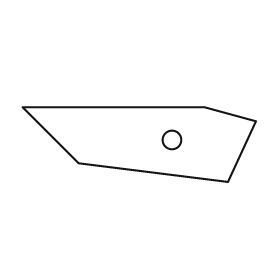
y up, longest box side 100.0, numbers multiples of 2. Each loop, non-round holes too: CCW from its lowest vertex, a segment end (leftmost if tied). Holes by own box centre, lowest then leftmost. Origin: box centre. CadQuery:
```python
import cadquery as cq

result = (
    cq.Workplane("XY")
    .moveTo(38.0, -16.0)
    .lineTo(50.0, 10.0)
    .lineTo(28.0, 16.0)
    .lineTo(-50.0, 16.0)
    .lineTo(-26.0, -8.0)
    .close()
    .moveTo(14.0, 2.0)
    .circle(4.0)
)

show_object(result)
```